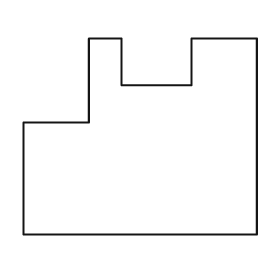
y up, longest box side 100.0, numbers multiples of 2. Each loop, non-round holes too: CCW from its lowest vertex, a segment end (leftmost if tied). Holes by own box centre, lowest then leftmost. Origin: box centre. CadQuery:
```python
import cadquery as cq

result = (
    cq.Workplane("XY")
    .moveTo(-50.0, -42.0)
    .lineTo(50.0, -42.0)
    .lineTo(50.0, 42.0)
    .lineTo(22.0, 42.0)
    .lineTo(22.0, 22.0)
    .lineTo(-8.0, 22.0)
    .lineTo(-8.0, 42.0)
    .lineTo(-22.0, 42.0)
    .lineTo(-22.0, 6.0)
    .lineTo(-50.0, 6.0)
    .close()
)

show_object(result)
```